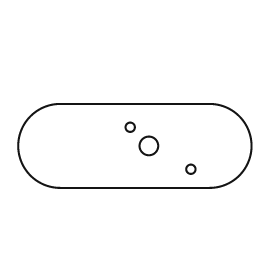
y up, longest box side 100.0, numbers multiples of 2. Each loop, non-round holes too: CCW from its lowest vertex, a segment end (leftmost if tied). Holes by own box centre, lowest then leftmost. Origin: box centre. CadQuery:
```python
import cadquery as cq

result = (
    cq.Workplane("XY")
    .moveTo(-32.0, -18.0)
    .lineTo(32.0, -18.0)
    .threePointArc((50.0, 0.0), (32.0, 18.0))
    .lineTo(-32.0, 18.0)
    .threePointArc((-50.0, 0.0), (-32.0, -18.0))
    .close()
    .moveTo(24.0, -10.0)
    .circle(2.0)
    .moveTo(6.0, 0.0)
    .circle(4.0)
    .moveTo(-2.0, 8.0)
    .circle(2.0)
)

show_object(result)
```